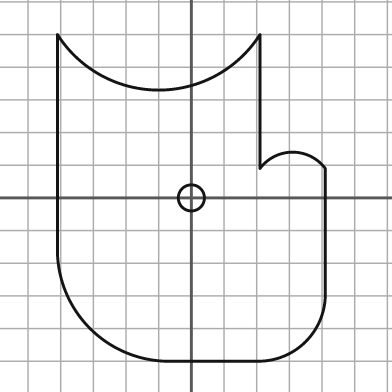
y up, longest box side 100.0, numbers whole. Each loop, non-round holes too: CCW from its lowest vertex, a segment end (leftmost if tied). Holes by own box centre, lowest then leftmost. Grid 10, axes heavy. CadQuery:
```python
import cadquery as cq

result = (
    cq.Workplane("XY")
    .moveTo(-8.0, -50.0)
    .lineTo(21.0, -50.0)
    .threePointArc((35.0, -44.0), (41.0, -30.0))
    .lineTo(41.0, 9.0)
    .threePointArc((31.0, 14.0), (21.0, 9.0))
    .lineTo(21.0, 50.0)
    .threePointArc((-10.0, 33.0), (-41.0, 50.0))
    .lineTo(-41.0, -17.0)
    .threePointArc((-31.0, -40.0), (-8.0, -50.0))
    .close()
    .moveTo(0.0, 0.0)
    .circle(4.0)
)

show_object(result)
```